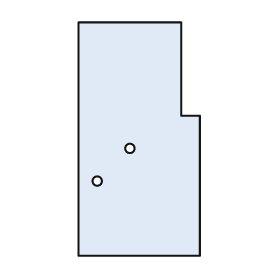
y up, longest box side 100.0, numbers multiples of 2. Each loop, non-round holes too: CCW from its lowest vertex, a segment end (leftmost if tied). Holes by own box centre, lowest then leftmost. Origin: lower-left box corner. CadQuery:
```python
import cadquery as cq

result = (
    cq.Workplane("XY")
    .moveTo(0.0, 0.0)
    .lineTo(52.0, 0.0)
    .lineTo(52.0, 60.0)
    .lineTo(44.0, 60.0)
    .lineTo(44.0, 100.0)
    .lineTo(0.0, 100.0)
    .close()
    .moveTo(8.0, 32.0)
    .circle(2.0)
    .moveTo(22.0, 46.0)
    .circle(2.0)
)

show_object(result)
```